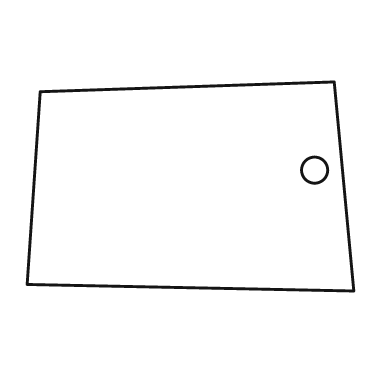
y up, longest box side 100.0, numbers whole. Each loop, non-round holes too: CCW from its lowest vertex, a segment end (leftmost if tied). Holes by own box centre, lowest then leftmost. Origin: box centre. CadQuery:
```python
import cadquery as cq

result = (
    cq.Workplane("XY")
    .moveTo(50.0, -32.0)
    .lineTo(44.0, 32.0)
    .lineTo(-46.0, 29.0)
    .lineTo(-50.0, -30.0)
    .close()
    .moveTo(38.0, 5.0)
    .circle(4.0)
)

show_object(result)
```